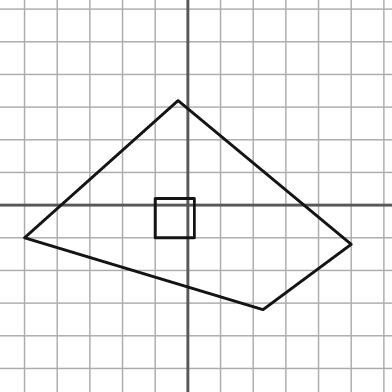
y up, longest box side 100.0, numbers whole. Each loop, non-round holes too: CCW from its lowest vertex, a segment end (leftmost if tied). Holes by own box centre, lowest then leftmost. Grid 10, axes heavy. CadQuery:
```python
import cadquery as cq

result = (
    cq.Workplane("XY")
    .moveTo(23.0, -32.0)
    .lineTo(50.0, -12.0)
    .lineTo(-3.0, 32.0)
    .lineTo(-50.0, -10.0)
    .close()
    .moveTo(-10.0, -10.0)
    .lineTo(2.0, -10.0)
    .lineTo(2.0, 2.0)
    .lineTo(-10.0, 2.0)
    .close()
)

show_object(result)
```